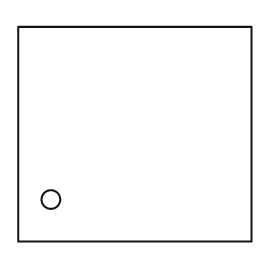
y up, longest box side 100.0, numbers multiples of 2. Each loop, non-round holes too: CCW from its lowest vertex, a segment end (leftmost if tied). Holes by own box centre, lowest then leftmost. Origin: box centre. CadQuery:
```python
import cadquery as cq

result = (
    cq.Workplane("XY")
    .moveTo(-50.0, -46.0)
    .lineTo(50.0, -46.0)
    .lineTo(50.0, 46.0)
    .lineTo(-50.0, 46.0)
    .close()
    .moveTo(-36.0, -28.0)
    .circle(4.0)
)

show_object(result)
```